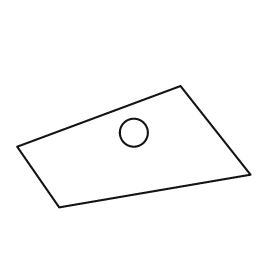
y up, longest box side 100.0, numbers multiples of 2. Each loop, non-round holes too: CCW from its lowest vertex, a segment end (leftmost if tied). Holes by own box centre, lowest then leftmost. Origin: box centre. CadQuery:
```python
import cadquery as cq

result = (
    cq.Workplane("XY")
    .moveTo(-32.0, -26.0)
    .lineTo(50.0, -12.0)
    .lineTo(20.0, 26.0)
    .lineTo(-50.0, 0.0)
    .close()
    .moveTo(0.0, 6.0)
    .circle(6.0)
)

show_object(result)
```